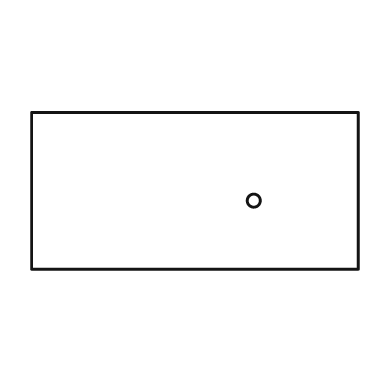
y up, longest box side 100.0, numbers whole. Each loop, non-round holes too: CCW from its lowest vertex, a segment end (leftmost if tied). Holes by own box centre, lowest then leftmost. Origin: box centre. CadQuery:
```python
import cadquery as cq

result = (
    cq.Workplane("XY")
    .moveTo(-50.0, -24.0)
    .lineTo(50.0, -24.0)
    .lineTo(50.0, 24.0)
    .lineTo(-50.0, 24.0)
    .close()
    .moveTo(18.0, -3.0)
    .circle(2.0)
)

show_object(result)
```